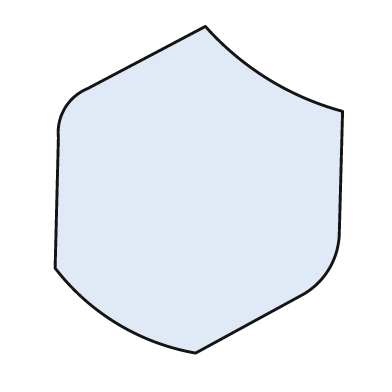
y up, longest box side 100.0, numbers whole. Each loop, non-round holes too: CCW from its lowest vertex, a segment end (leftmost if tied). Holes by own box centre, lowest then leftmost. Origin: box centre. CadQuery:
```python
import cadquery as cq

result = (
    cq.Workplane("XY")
    .moveTo(-1.0, -50.0)
    .lineTo(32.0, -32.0)
    .threePointArc((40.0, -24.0), (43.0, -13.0))
    .lineTo(44.0, 24.0)
    .threePointArc((21.0, 34.0), (2.0, 50.0))
    .lineTo(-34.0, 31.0)
    .threePointArc((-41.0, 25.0), (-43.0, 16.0))
    .lineTo(-44.0, -24.0)
    .threePointArc((-25.0, -41.0), (-1.0, -50.0))
    .close()
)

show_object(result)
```